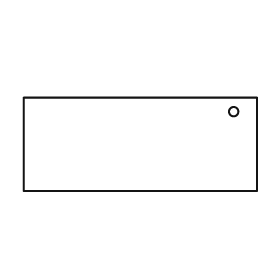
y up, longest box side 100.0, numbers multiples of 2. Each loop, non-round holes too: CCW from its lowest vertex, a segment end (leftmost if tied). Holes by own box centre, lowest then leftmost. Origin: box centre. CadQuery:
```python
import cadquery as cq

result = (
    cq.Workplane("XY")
    .moveTo(-50.0, -20.0)
    .lineTo(50.0, -20.0)
    .lineTo(50.0, 20.0)
    .lineTo(-50.0, 20.0)
    .close()
    .moveTo(40.0, 14.0)
    .circle(2.0)
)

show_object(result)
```